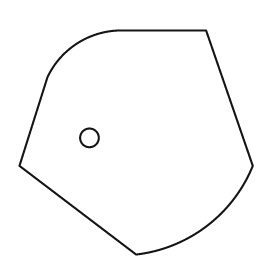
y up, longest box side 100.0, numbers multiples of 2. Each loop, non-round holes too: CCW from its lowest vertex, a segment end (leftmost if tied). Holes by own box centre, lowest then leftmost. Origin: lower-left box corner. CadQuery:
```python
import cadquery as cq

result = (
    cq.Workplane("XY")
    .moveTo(50.0, 0.0)
    .threePointArc((80.0, 12.0), (100.0, 38.0))
    .lineTo(80.0, 96.0)
    .lineTo(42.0, 96.0)
    .threePointArc((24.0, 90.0), (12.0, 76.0))
    .lineTo(0.0, 38.0)
    .close()
    .moveTo(30.0, 50.0)
    .circle(4.0)
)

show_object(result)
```